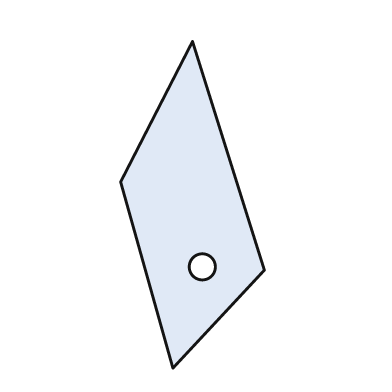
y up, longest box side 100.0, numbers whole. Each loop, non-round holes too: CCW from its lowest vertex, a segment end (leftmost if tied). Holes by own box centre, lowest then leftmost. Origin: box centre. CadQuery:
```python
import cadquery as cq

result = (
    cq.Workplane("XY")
    .moveTo(-6.0, -50.0)
    .lineTo(22.0, -20.0)
    .lineTo(0.0, 50.0)
    .lineTo(-22.0, 7.0)
    .close()
    .moveTo(3.0, -19.0)
    .circle(4.0)
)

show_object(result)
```